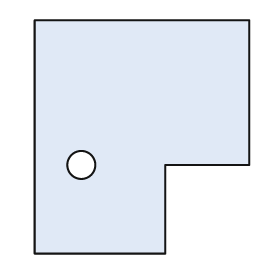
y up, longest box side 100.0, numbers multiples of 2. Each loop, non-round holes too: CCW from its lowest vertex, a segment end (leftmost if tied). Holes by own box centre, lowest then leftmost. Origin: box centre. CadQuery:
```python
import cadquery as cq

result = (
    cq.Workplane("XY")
    .moveTo(-46.0, -50.0)
    .lineTo(10.0, -50.0)
    .lineTo(10.0, -12.0)
    .lineTo(46.0, -12.0)
    .lineTo(46.0, 50.0)
    .lineTo(-46.0, 50.0)
    .close()
    .moveTo(-26.0, -12.0)
    .circle(6.0)
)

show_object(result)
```